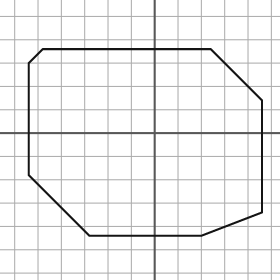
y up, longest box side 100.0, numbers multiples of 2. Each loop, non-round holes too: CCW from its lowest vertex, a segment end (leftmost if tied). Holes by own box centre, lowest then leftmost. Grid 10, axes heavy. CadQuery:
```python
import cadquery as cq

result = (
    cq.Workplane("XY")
    .moveTo(-28.0, -44.0)
    .lineTo(20.0, -44.0)
    .lineTo(46.0, -34.0)
    .lineTo(46.0, 14.0)
    .lineTo(24.0, 36.0)
    .lineTo(-48.0, 36.0)
    .lineTo(-54.0, 30.0)
    .lineTo(-54.0, -18.0)
    .close()
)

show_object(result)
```